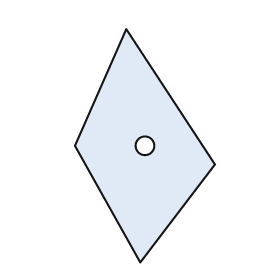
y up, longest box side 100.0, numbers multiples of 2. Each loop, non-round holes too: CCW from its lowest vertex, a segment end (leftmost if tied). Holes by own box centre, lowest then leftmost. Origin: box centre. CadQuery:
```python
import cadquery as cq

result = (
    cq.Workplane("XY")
    .moveTo(-2.0, -50.0)
    .lineTo(30.0, -8.0)
    .lineTo(-8.0, 50.0)
    .lineTo(-30.0, 0.0)
    .close()
    .moveTo(0.0, 0.0)
    .circle(4.0)
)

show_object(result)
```